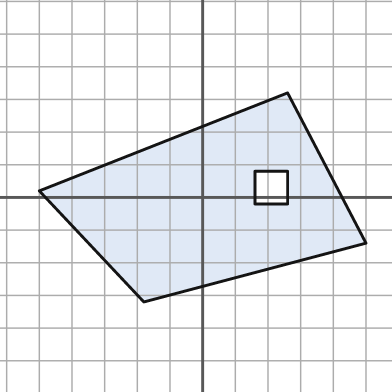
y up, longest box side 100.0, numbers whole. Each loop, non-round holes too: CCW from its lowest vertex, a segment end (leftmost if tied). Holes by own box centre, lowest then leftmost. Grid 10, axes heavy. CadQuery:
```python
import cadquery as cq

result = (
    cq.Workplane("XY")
    .moveTo(-18.0, -32.0)
    .lineTo(50.0, -14.0)
    .lineTo(26.0, 32.0)
    .lineTo(-50.0, 2.0)
    .close()
    .moveTo(16.0, -2.0)
    .lineTo(26.0, -2.0)
    .lineTo(26.0, 8.0)
    .lineTo(16.0, 8.0)
    .close()
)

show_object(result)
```